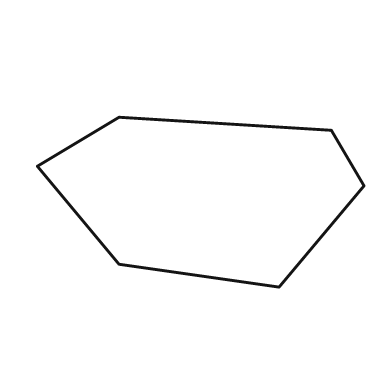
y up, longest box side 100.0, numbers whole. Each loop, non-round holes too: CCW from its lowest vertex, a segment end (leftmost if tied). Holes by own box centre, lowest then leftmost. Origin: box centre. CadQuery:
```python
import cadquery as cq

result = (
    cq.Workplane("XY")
    .moveTo(24.0, -26.0)
    .lineTo(50.0, 5.0)
    .lineTo(40.0, 22.0)
    .lineTo(-25.0, 26.0)
    .lineTo(-50.0, 11.0)
    .lineTo(-25.0, -19.0)
    .close()
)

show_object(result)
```